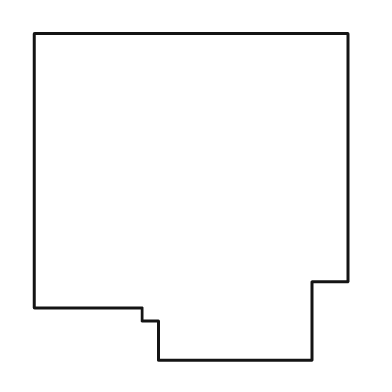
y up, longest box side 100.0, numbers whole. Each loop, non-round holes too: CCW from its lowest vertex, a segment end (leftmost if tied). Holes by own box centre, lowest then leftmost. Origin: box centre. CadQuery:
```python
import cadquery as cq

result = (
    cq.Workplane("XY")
    .moveTo(-10.0, -50.0)
    .lineTo(37.0, -50.0)
    .lineTo(37.0, -26.0)
    .lineTo(48.0, -26.0)
    .lineTo(48.0, 50.0)
    .lineTo(-48.0, 50.0)
    .lineTo(-48.0, -34.0)
    .lineTo(-15.0, -34.0)
    .lineTo(-15.0, -38.0)
    .lineTo(-10.0, -38.0)
    .close()
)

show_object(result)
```